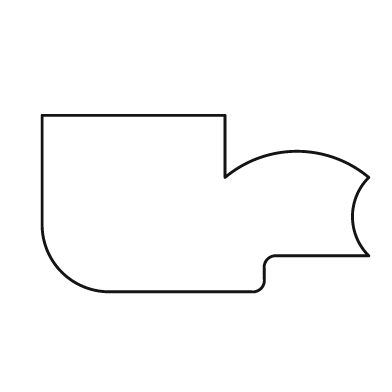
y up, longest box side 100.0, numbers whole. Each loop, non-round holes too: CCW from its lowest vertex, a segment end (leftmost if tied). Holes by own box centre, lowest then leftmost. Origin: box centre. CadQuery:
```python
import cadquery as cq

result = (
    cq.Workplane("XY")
    .moveTo(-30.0, -27.0)
    .lineTo(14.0, -27.0)
    .threePointArc((17.0, -26.0), (18.0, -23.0))
    .lineTo(18.0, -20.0)
    .threePointArc((19.0, -17.0), (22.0, -16.0))
    .lineTo(50.0, -16.0)
    .threePointArc((45.0, -4.0), (50.0, 8.0))
    .threePointArc((28.0, 16.0), (6.0, 8.0))
    .lineTo(6.0, 27.0)
    .lineTo(-50.0, 27.0)
    .lineTo(-50.0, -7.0)
    .threePointArc((-44.0, -21.0), (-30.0, -27.0))
    .close()
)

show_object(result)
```